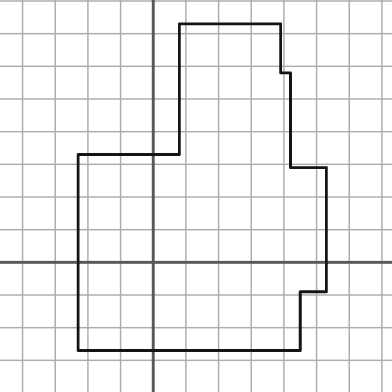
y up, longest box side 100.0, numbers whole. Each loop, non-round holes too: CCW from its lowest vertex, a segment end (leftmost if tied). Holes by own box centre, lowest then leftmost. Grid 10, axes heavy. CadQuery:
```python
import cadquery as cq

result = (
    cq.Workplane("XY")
    .moveTo(-23.0, -27.0)
    .lineTo(45.0, -27.0)
    .lineTo(45.0, -9.0)
    .lineTo(53.0, -9.0)
    .lineTo(53.0, 29.0)
    .lineTo(42.0, 29.0)
    .lineTo(42.0, 58.0)
    .lineTo(39.0, 58.0)
    .lineTo(39.0, 73.0)
    .lineTo(8.0, 73.0)
    .lineTo(8.0, 33.0)
    .lineTo(-23.0, 33.0)
    .close()
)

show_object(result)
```